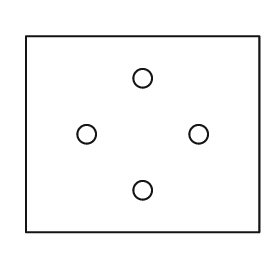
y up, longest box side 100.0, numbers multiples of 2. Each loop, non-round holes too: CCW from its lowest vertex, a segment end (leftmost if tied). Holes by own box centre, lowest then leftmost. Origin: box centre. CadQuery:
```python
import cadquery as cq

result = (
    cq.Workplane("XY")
    .moveTo(-50.0, -42.0)
    .lineTo(50.0, -42.0)
    .lineTo(50.0, 42.0)
    .lineTo(-50.0, 42.0)
    .close()
    .moveTo(0.0, -24.0)
    .circle(4.0)
    .moveTo(-24.0, 0.0)
    .circle(4.0)
    .moveTo(24.0, 0.0)
    .circle(4.0)
    .moveTo(0.0, 24.0)
    .circle(4.0)
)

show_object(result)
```